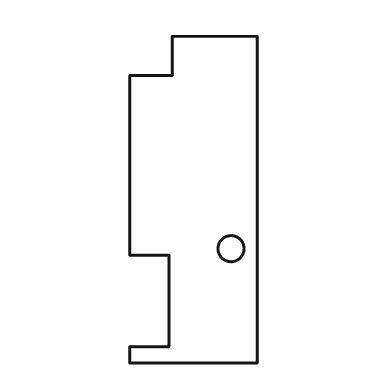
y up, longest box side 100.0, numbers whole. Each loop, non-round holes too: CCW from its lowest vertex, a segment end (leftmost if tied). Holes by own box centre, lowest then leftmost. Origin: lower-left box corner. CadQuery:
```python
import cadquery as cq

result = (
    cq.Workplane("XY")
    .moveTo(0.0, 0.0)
    .lineTo(39.0, 0.0)
    .lineTo(39.0, 100.0)
    .lineTo(13.0, 100.0)
    .lineTo(13.0, 88.0)
    .lineTo(0.0, 88.0)
    .lineTo(0.0, 33.0)
    .lineTo(12.0, 33.0)
    .lineTo(12.0, 5.0)
    .lineTo(0.0, 5.0)
    .close()
    .moveTo(31.0, 35.0)
    .circle(4.0)
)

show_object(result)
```